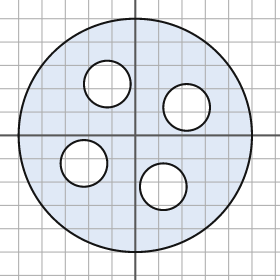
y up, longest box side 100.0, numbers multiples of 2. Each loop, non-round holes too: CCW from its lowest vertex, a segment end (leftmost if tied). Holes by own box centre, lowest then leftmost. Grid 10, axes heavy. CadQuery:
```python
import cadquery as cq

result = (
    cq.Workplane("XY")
    .moveTo(0.0, 0.0)
    .circle(50.0)
    .moveTo(12.0, -22.0)
    .circle(10.0)
    .moveTo(-22.0, -12.0)
    .circle(10.0)
    .moveTo(22.0, 12.0)
    .circle(10.0)
    .moveTo(-12.0, 22.0)
    .circle(10.0)
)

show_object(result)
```